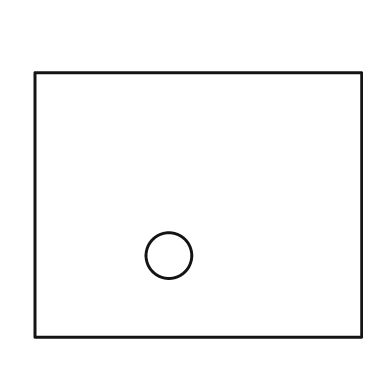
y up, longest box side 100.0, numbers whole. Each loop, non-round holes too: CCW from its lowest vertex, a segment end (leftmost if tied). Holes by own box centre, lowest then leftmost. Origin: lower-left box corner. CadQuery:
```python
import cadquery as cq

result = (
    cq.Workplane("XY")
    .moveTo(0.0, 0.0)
    .lineTo(100.0, 0.0)
    .lineTo(100.0, 81.0)
    .lineTo(0.0, 81.0)
    .close()
    .moveTo(41.0, 25.0)
    .circle(7.0)
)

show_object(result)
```